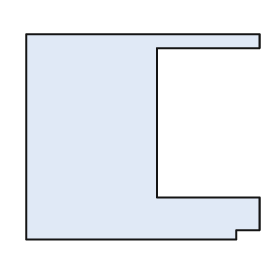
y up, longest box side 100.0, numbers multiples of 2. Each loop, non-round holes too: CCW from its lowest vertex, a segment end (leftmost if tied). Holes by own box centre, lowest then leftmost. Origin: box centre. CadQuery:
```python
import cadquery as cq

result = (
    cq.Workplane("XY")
    .moveTo(-50.0, -44.0)
    .lineTo(40.0, -44.0)
    .lineTo(40.0, -40.0)
    .lineTo(50.0, -40.0)
    .lineTo(50.0, -26.0)
    .lineTo(6.0, -26.0)
    .lineTo(6.0, 38.0)
    .lineTo(50.0, 38.0)
    .lineTo(50.0, 44.0)
    .lineTo(-50.0, 44.0)
    .close()
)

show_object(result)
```